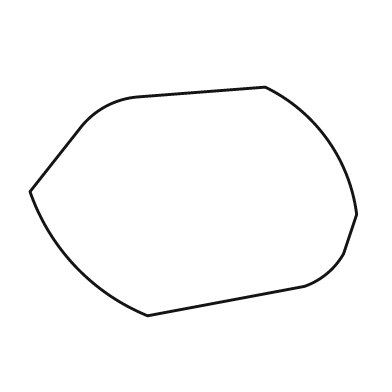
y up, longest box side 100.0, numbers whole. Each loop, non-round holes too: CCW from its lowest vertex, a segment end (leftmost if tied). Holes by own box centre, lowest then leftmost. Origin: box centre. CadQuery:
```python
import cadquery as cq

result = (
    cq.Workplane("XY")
    .moveTo(-14.0, -35.0)
    .lineTo(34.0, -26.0)
    .threePointArc((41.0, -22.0), (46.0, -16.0))
    .lineTo(50.0, -4.0)
    .threePointArc((41.0, 19.0), (22.0, 35.0))
    .lineTo(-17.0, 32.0)
    .threePointArc((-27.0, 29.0), (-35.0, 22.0))
    .lineTo(-50.0, 3.0)
    .threePointArc((-36.0, -20.0), (-14.0, -35.0))
    .close()
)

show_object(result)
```